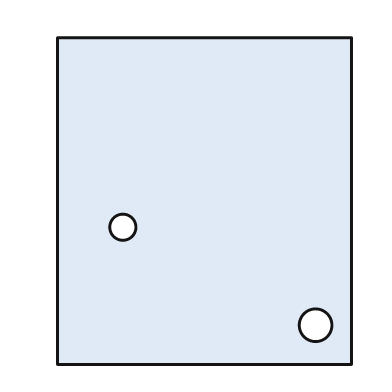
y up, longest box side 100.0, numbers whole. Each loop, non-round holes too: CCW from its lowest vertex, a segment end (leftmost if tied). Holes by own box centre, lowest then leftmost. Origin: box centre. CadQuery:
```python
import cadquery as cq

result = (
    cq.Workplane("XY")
    .moveTo(-45.0, -50.0)
    .lineTo(45.0, -50.0)
    .lineTo(45.0, 50.0)
    .lineTo(-45.0, 50.0)
    .close()
    .moveTo(34.0, -38.0)
    .circle(5.0)
    .moveTo(-25.0, -8.0)
    .circle(4.0)
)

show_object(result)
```